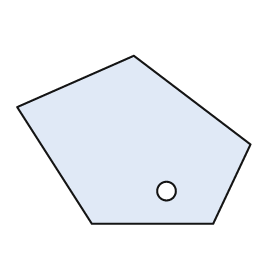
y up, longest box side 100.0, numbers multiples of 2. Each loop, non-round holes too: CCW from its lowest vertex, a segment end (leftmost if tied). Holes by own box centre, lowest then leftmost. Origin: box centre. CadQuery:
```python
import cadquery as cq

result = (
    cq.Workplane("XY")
    .moveTo(-18.0, -36.0)
    .lineTo(34.0, -36.0)
    .lineTo(50.0, -2.0)
    .lineTo(0.0, 36.0)
    .lineTo(-50.0, 14.0)
    .close()
    .moveTo(14.0, -22.0)
    .circle(4.0)
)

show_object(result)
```